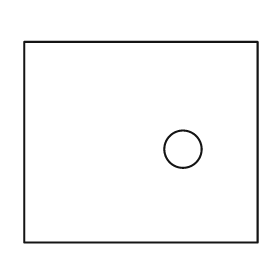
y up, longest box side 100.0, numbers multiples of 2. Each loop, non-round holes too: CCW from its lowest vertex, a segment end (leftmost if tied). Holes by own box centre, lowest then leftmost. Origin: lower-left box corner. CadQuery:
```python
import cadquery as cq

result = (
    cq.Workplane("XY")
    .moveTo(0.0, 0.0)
    .lineTo(100.0, 0.0)
    .lineTo(100.0, 86.0)
    .lineTo(0.0, 86.0)
    .close()
    .moveTo(68.0, 40.0)
    .circle(8.0)
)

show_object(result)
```